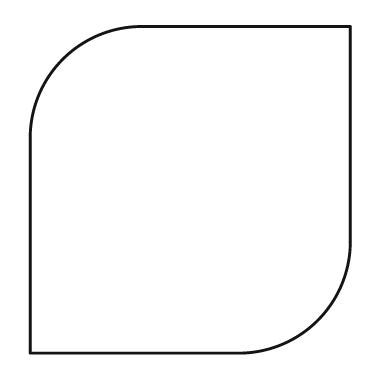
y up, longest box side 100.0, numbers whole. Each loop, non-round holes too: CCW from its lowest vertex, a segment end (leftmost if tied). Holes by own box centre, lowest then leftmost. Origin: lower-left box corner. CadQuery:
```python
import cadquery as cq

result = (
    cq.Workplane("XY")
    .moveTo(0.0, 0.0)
    .lineTo(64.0, 0.0)
    .threePointArc((88.0, 10.0), (98.0, 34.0))
    .lineTo(98.0, 100.0)
    .lineTo(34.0, 100.0)
    .threePointArc((10.0, 90.0), (0.0, 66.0))
    .close()
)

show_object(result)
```